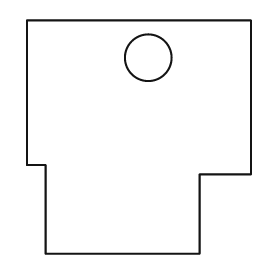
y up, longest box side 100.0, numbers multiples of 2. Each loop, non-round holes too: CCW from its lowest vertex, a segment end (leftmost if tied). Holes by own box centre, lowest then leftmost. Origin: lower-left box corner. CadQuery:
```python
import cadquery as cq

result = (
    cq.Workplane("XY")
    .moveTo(8.0, 0.0)
    .lineTo(74.0, 0.0)
    .lineTo(74.0, 34.0)
    .lineTo(96.0, 34.0)
    .lineTo(96.0, 100.0)
    .lineTo(0.0, 100.0)
    .lineTo(0.0, 38.0)
    .lineTo(8.0, 38.0)
    .close()
    .moveTo(52.0, 84.0)
    .circle(10.0)
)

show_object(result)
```